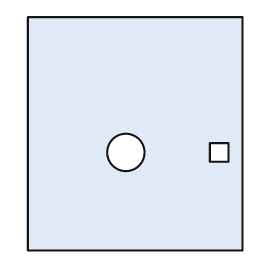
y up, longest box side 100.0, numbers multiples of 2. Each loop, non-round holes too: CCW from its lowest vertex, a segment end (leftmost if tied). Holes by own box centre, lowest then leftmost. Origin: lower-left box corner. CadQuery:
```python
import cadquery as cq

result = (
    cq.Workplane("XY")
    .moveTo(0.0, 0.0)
    .lineTo(92.0, 0.0)
    .lineTo(92.0, 100.0)
    .lineTo(0.0, 100.0)
    .close()
    .moveTo(42.0, 42.0)
    .circle(8.0)
    .moveTo(78.0, 38.0)
    .lineTo(86.0, 38.0)
    .lineTo(86.0, 46.0)
    .lineTo(78.0, 46.0)
    .close()
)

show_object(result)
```